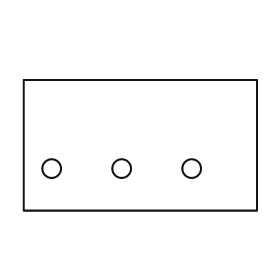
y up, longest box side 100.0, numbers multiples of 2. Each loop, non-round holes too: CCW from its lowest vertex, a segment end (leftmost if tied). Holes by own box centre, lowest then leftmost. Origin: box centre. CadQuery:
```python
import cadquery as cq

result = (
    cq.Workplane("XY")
    .moveTo(-50.0, -28.0)
    .lineTo(50.0, -28.0)
    .lineTo(50.0, 28.0)
    .lineTo(-50.0, 28.0)
    .close()
    .moveTo(-38.0, -10.0)
    .circle(4.0)
    .moveTo(-8.0, -10.0)
    .circle(4.0)
    .moveTo(22.0, -10.0)
    .circle(4.0)
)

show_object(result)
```